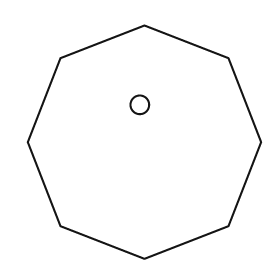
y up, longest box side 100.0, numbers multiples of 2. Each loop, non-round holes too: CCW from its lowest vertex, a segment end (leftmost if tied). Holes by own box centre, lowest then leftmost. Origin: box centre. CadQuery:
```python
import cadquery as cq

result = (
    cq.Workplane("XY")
    .moveTo(0.0, -50.0)
    .lineTo(36.0, -36.0)
    .lineTo(50.0, 0.0)
    .lineTo(36.0, 36.0)
    .lineTo(0.0, 50.0)
    .lineTo(-36.0, 36.0)
    .lineTo(-50.0, 0.0)
    .lineTo(-36.0, -36.0)
    .close()
    .moveTo(-2.0, 16.0)
    .circle(4.0)
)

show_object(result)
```